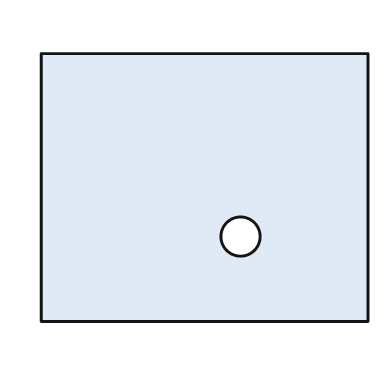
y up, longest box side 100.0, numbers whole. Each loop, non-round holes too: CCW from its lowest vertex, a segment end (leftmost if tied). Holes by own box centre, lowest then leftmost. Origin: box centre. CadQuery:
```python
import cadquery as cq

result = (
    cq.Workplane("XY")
    .moveTo(-50.0, -41.0)
    .lineTo(50.0, -41.0)
    .lineTo(50.0, 41.0)
    .lineTo(-50.0, 41.0)
    .close()
    .moveTo(11.0, -15.0)
    .circle(6.0)
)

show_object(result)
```